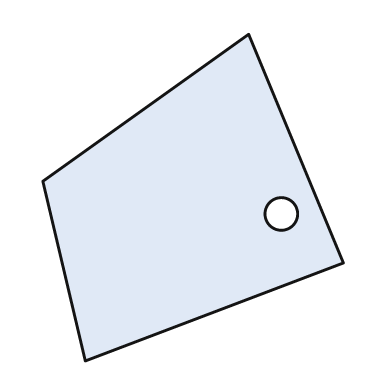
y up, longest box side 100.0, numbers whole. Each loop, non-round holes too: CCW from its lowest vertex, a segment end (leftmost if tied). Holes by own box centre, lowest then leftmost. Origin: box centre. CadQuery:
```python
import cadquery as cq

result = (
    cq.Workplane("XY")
    .moveTo(-33.0, -50.0)
    .lineTo(46.0, -20.0)
    .lineTo(17.0, 50.0)
    .lineTo(-46.0, 5.0)
    .close()
    .moveTo(27.0, -5.0)
    .circle(5.0)
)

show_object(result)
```